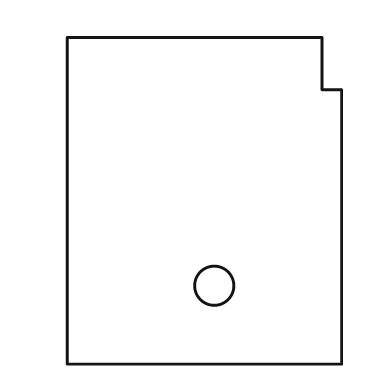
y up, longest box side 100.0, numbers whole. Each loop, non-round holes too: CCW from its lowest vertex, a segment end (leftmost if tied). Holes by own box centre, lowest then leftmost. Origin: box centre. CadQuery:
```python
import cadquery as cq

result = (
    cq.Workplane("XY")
    .moveTo(-42.0, -50.0)
    .lineTo(42.0, -50.0)
    .lineTo(42.0, 34.0)
    .lineTo(36.0, 34.0)
    .lineTo(36.0, 50.0)
    .lineTo(-42.0, 50.0)
    .close()
    .moveTo(3.0, -26.0)
    .circle(6.0)
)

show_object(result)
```